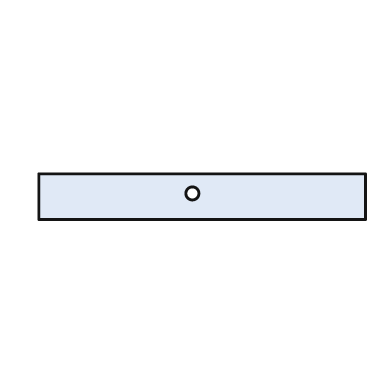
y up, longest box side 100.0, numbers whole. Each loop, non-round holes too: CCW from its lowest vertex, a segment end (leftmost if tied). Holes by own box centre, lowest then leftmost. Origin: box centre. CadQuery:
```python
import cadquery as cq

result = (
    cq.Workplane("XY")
    .moveTo(-50.0, -7.0)
    .lineTo(50.0, -7.0)
    .lineTo(50.0, 7.0)
    .lineTo(-50.0, 7.0)
    .close()
    .moveTo(-3.0, 1.0)
    .circle(2.0)
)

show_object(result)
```